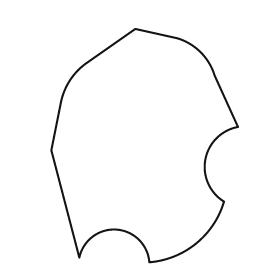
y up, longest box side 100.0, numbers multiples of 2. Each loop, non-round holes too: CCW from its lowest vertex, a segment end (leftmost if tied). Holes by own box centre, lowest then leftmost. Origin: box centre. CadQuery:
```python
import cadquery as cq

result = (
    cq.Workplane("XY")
    .moveTo(2.0, -50.0)
    .threePointArc((22.0, -42.0), (34.0, -24.0))
    .threePointArc((26.0, -6.0), (40.0, 8.0))
    .lineTo(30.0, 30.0)
    .threePointArc((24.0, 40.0), (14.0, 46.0))
    .lineTo(-4.0, 50.0)
    .lineTo(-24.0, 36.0)
    .threePointArc((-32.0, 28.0), (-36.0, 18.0))
    .lineTo(-40.0, -2.0)
    .lineTo(-28.0, -48.0)
    .threePointArc((-12.0, -36.0), (2.0, -50.0))
    .close()
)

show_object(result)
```